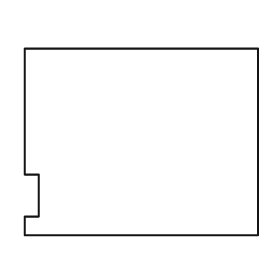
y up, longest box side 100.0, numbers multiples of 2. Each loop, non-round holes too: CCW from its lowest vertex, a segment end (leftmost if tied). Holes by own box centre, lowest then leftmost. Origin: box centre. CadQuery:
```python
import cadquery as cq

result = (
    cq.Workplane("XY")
    .moveTo(-50.0, -40.0)
    .lineTo(50.0, -40.0)
    .lineTo(50.0, 40.0)
    .lineTo(-50.0, 40.0)
    .lineTo(-50.0, -14.0)
    .lineTo(-44.0, -14.0)
    .lineTo(-44.0, -32.0)
    .lineTo(-50.0, -32.0)
    .close()
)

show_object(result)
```